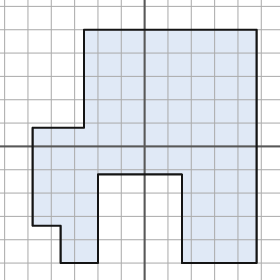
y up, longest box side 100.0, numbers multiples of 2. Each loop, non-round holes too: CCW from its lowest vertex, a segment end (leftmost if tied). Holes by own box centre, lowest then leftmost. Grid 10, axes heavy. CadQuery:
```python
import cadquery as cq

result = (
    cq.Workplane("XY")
    .moveTo(-36.0, -50.0)
    .lineTo(-20.0, -50.0)
    .lineTo(-20.0, -12.0)
    .lineTo(16.0, -12.0)
    .lineTo(16.0, -50.0)
    .lineTo(48.0, -50.0)
    .lineTo(48.0, 50.0)
    .lineTo(-26.0, 50.0)
    .lineTo(-26.0, 8.0)
    .lineTo(-48.0, 8.0)
    .lineTo(-48.0, -34.0)
    .lineTo(-36.0, -34.0)
    .close()
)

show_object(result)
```